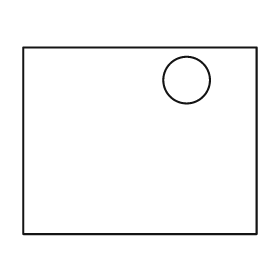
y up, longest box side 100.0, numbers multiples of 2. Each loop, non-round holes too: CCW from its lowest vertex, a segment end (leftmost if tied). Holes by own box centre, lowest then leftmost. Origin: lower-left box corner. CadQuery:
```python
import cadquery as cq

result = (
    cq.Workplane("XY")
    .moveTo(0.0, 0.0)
    .lineTo(100.0, 0.0)
    .lineTo(100.0, 80.0)
    .lineTo(0.0, 80.0)
    .close()
    .moveTo(70.0, 66.0)
    .circle(10.0)
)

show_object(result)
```